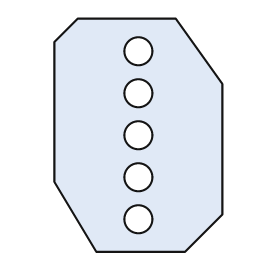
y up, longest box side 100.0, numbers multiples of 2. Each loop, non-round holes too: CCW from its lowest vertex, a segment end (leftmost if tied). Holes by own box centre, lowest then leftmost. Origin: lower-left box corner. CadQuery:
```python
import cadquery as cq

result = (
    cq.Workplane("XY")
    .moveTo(18.0, 0.0)
    .lineTo(56.0, 0.0)
    .lineTo(72.0, 16.0)
    .lineTo(72.0, 72.0)
    .lineTo(52.0, 100.0)
    .lineTo(10.0, 100.0)
    .lineTo(0.0, 90.0)
    .lineTo(0.0, 30.0)
    .close()
    .moveTo(36.0, 14.0)
    .circle(6.0)
    .moveTo(36.0, 32.0)
    .circle(6.0)
    .moveTo(36.0, 50.0)
    .circle(6.0)
    .moveTo(36.0, 68.0)
    .circle(6.0)
    .moveTo(36.0, 86.0)
    .circle(6.0)
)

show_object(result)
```